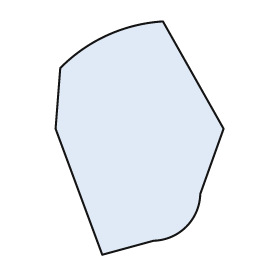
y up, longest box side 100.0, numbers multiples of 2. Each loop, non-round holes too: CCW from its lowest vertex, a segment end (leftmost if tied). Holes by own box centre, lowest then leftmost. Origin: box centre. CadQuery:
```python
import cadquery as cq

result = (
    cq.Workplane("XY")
    .moveTo(-16.0, -50.0)
    .lineTo(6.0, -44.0)
    .threePointArc((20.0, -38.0), (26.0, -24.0))
    .lineTo(36.0, 4.0)
    .lineTo(10.0, 50.0)
    .threePointArc((-14.0, 44.0), (-34.0, 30.0))
    .lineTo(-36.0, 4.0)
    .close()
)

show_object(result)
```